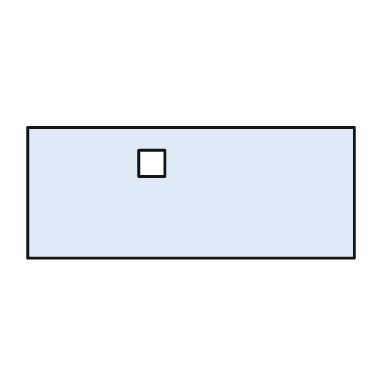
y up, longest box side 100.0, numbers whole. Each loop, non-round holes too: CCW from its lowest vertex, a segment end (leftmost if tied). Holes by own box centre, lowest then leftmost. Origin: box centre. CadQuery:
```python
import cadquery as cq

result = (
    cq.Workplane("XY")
    .moveTo(-50.0, -20.0)
    .lineTo(50.0, -20.0)
    .lineTo(50.0, 20.0)
    .lineTo(-50.0, 20.0)
    .close()
    .moveTo(-16.0, 5.0)
    .lineTo(-8.0, 5.0)
    .lineTo(-8.0, 13.0)
    .lineTo(-16.0, 13.0)
    .close()
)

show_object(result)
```